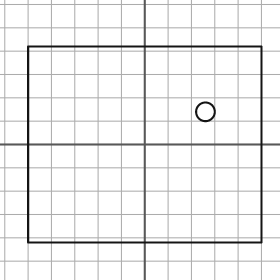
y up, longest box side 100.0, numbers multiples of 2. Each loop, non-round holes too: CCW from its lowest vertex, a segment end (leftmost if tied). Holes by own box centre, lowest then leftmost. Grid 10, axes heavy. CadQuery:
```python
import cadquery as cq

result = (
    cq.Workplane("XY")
    .moveTo(-50.0, -42.0)
    .lineTo(50.0, -42.0)
    .lineTo(50.0, 42.0)
    .lineTo(-50.0, 42.0)
    .close()
    .moveTo(26.0, 14.0)
    .circle(4.0)
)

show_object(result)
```